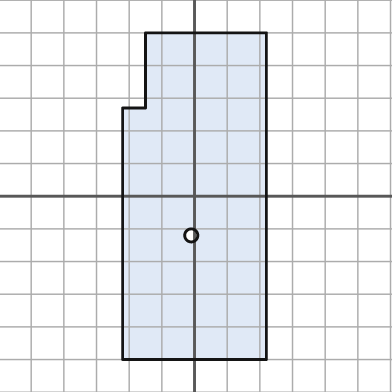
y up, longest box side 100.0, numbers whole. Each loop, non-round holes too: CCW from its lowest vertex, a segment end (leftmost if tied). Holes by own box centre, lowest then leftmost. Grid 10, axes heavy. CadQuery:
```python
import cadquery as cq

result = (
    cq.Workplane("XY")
    .moveTo(-22.0, -50.0)
    .lineTo(22.0, -50.0)
    .lineTo(22.0, 50.0)
    .lineTo(-15.0, 50.0)
    .lineTo(-15.0, 27.0)
    .lineTo(-22.0, 27.0)
    .close()
    .moveTo(-1.0, -12.0)
    .circle(2.0)
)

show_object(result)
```